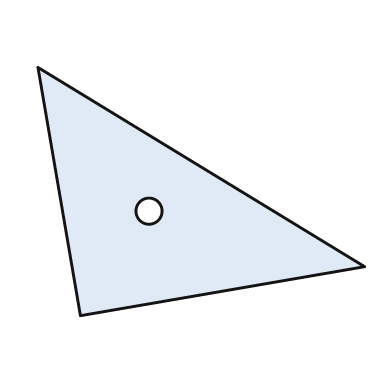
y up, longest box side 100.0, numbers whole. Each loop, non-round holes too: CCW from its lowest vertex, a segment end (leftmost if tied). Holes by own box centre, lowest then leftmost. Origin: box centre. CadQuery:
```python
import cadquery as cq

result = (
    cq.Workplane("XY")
    .moveTo(-37.0, -38.0)
    .lineTo(50.0, -23.0)
    .lineTo(-50.0, 38.0)
    .close()
    .moveTo(-16.0, -6.0)
    .circle(4.0)
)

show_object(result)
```